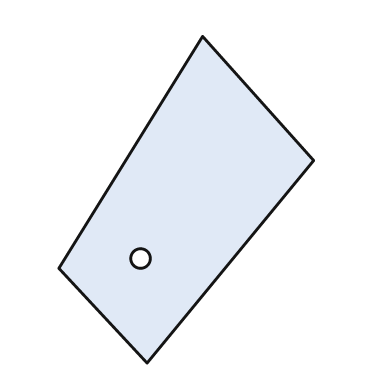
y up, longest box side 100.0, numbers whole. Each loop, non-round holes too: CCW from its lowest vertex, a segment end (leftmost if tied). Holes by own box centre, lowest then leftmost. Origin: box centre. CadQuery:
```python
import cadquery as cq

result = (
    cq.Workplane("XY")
    .moveTo(-12.0, -50.0)
    .lineTo(39.0, 12.0)
    .lineTo(5.0, 50.0)
    .lineTo(-39.0, -21.0)
    .close()
    .moveTo(-14.0, -18.0)
    .circle(3.0)
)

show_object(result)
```